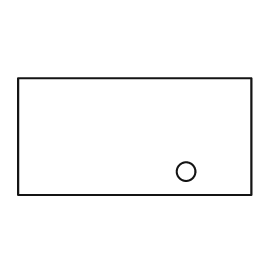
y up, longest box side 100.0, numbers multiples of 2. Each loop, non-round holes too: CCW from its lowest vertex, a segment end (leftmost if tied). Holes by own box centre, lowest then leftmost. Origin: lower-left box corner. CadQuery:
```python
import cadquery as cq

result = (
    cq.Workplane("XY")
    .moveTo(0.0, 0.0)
    .lineTo(100.0, 0.0)
    .lineTo(100.0, 50.0)
    .lineTo(0.0, 50.0)
    .close()
    .moveTo(72.0, 10.0)
    .circle(4.0)
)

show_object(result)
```